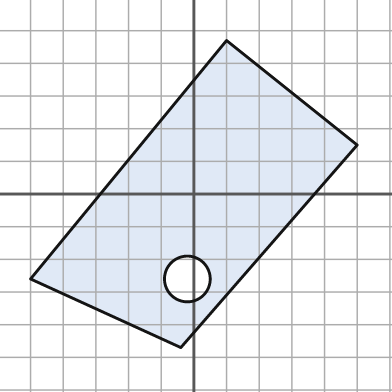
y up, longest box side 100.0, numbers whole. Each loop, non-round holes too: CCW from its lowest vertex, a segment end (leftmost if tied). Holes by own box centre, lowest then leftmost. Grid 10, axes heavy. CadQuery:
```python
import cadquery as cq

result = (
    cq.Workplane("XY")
    .moveTo(-4.0, -47.0)
    .lineTo(50.0, 15.0)
    .lineTo(10.0, 47.0)
    .lineTo(-50.0, -26.0)
    .close()
    .moveTo(-2.0, -26.0)
    .circle(7.0)
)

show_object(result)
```